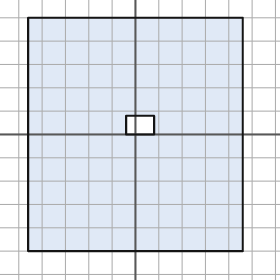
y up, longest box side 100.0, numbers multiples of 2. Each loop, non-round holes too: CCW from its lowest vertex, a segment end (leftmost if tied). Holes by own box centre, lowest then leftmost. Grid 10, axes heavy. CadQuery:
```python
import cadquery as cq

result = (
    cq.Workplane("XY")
    .moveTo(-46.0, -50.0)
    .lineTo(46.0, -50.0)
    .lineTo(46.0, 50.0)
    .lineTo(-46.0, 50.0)
    .close()
    .moveTo(-4.0, 0.0)
    .lineTo(8.0, 0.0)
    .lineTo(8.0, 8.0)
    .lineTo(-4.0, 8.0)
    .close()
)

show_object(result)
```